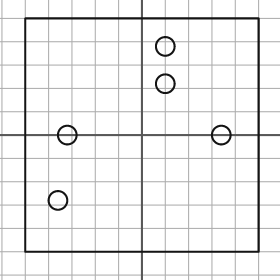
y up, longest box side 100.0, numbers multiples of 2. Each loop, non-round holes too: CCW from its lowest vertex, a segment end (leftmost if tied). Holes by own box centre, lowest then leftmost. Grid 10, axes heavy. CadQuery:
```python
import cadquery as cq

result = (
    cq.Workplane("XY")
    .moveTo(-50.0, -50.0)
    .lineTo(50.0, -50.0)
    .lineTo(50.0, 50.0)
    .lineTo(-50.0, 50.0)
    .close()
    .moveTo(-36.0, -28.0)
    .circle(4.0)
    .moveTo(-32.0, 0.0)
    .circle(4.0)
    .moveTo(34.0, 0.0)
    .circle(4.0)
    .moveTo(10.0, 22.0)
    .circle(4.0)
    .moveTo(10.0, 38.0)
    .circle(4.0)
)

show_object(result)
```